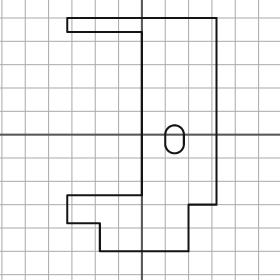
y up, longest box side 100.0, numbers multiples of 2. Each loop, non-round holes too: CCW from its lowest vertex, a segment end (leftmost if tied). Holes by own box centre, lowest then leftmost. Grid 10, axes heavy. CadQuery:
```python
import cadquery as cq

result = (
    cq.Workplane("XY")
    .moveTo(-18.0, -50.0)
    .lineTo(20.0, -50.0)
    .lineTo(20.0, -30.0)
    .lineTo(32.0, -30.0)
    .lineTo(32.0, 50.0)
    .lineTo(-32.0, 50.0)
    .lineTo(-32.0, 44.0)
    .lineTo(0.0, 44.0)
    .lineTo(0.0, -26.0)
    .lineTo(-32.0, -26.0)
    .lineTo(-32.0, -38.0)
    .lineTo(-18.0, -38.0)
    .close()
    .moveTo(10.0, -4.0)
    .threePointArc((14.0, -8.0), (18.0, -4.0))
    .lineTo(18.0, 0.0)
    .threePointArc((14.0, 4.0), (10.0, 0.0))
    .close()
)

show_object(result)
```